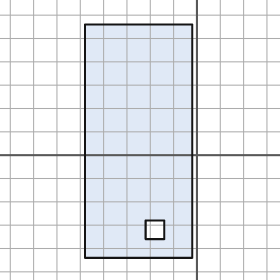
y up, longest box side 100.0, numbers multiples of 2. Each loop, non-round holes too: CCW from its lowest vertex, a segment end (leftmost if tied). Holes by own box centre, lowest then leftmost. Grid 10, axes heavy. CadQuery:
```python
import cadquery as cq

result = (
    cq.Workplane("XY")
    .moveTo(-48.0, -44.0)
    .lineTo(-2.0, -44.0)
    .lineTo(-2.0, 56.0)
    .lineTo(-48.0, 56.0)
    .close()
    .moveTo(-22.0, -36.0)
    .lineTo(-14.0, -36.0)
    .lineTo(-14.0, -28.0)
    .lineTo(-22.0, -28.0)
    .close()
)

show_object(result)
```